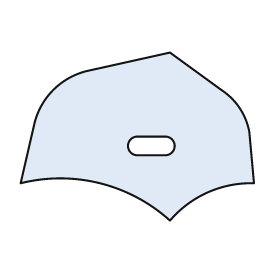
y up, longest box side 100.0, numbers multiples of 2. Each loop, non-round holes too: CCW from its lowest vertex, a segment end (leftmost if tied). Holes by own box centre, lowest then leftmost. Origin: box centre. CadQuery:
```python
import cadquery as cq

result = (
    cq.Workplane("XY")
    .moveTo(14.0, -36.0)
    .threePointArc((30.0, -24.0), (50.0, -20.0))
    .lineTo(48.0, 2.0)
    .threePointArc((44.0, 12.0), (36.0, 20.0))
    .lineTo(14.0, 36.0)
    .lineTo(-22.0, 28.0)
    .threePointArc((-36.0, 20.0), (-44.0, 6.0))
    .lineTo(-50.0, -20.0)
    .threePointArc((-16.0, -20.0), (14.0, -36.0))
    .close()
    .moveTo(0.0, -8.0)
    .lineTo(12.0, -8.0)
    .threePointArc((16.0, -4.0), (12.0, 0.0))
    .lineTo(0.0, 0.0)
    .threePointArc((-4.0, -4.0), (0.0, -8.0))
    .close()
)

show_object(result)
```